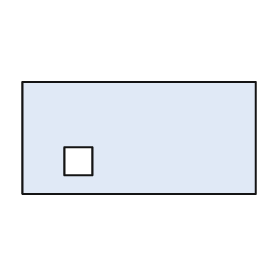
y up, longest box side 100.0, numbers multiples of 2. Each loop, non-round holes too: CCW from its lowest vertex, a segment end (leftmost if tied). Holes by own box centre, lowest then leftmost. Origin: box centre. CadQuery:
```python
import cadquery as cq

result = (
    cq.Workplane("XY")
    .moveTo(-50.0, -24.0)
    .lineTo(50.0, -24.0)
    .lineTo(50.0, 24.0)
    .lineTo(-50.0, 24.0)
    .close()
    .moveTo(-32.0, -16.0)
    .lineTo(-20.0, -16.0)
    .lineTo(-20.0, -4.0)
    .lineTo(-32.0, -4.0)
    .close()
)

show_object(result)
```